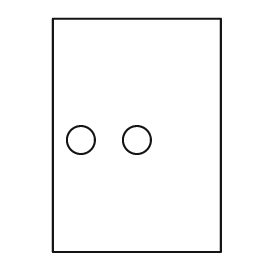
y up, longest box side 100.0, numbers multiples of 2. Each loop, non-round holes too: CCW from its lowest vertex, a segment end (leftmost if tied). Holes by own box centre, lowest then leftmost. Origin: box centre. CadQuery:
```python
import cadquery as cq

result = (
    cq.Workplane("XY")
    .moveTo(-36.0, -50.0)
    .lineTo(36.0, -50.0)
    .lineTo(36.0, 50.0)
    .lineTo(-36.0, 50.0)
    .close()
    .moveTo(-24.0, -2.0)
    .circle(6.0)
    .moveTo(0.0, -2.0)
    .circle(6.0)
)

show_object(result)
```